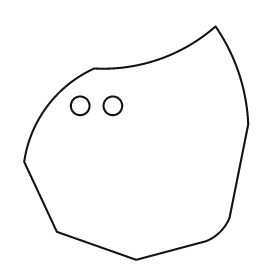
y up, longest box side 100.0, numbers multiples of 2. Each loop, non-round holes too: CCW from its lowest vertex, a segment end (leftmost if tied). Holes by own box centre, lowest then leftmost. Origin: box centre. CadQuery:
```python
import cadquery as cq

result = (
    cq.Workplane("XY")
    .moveTo(0.0, -50.0)
    .lineTo(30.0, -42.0)
    .threePointArc((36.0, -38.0), (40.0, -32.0))
    .lineTo(48.0, 8.0)
    .threePointArc((44.0, 30.0), (34.0, 50.0))
    .threePointArc((10.0, 36.0), (-18.0, 32.0))
    .threePointArc((-38.0, 16.0), (-48.0, -8.0))
    .lineTo(-34.0, -38.0)
    .close()
    .moveTo(-24.0, 16.0)
    .circle(4.0)
    .moveTo(-10.0, 16.0)
    .circle(4.0)
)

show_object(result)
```